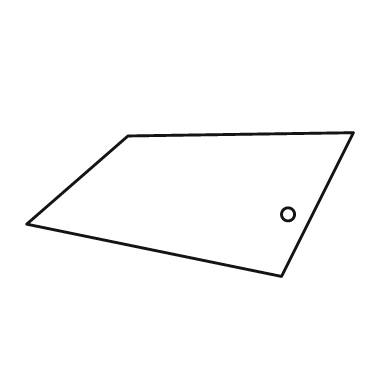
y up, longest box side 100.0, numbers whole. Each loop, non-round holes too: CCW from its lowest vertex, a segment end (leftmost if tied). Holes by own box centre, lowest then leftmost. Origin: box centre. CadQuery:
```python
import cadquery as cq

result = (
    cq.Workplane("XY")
    .moveTo(28.0, -22.0)
    .lineTo(50.0, 22.0)
    .lineTo(-19.0, 21.0)
    .lineTo(-50.0, -6.0)
    .close()
    .moveTo(30.0, -3.0)
    .circle(2.0)
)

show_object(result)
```